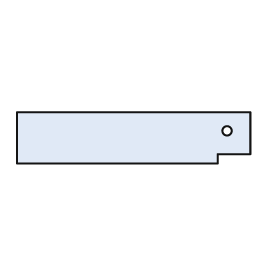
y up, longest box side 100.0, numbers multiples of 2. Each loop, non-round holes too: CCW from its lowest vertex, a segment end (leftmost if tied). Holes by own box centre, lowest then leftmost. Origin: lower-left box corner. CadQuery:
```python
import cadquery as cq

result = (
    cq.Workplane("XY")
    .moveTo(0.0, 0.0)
    .lineTo(86.0, 0.0)
    .lineTo(86.0, 4.0)
    .lineTo(100.0, 4.0)
    .lineTo(100.0, 22.0)
    .lineTo(0.0, 22.0)
    .close()
    .moveTo(90.0, 14.0)
    .circle(2.0)
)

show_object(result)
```